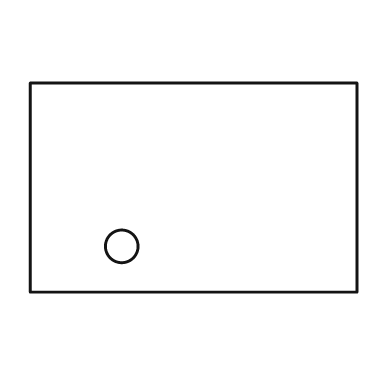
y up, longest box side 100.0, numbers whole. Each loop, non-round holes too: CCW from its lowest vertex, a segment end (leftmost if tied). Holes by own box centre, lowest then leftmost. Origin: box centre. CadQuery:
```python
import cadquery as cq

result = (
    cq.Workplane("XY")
    .moveTo(-50.0, -32.0)
    .lineTo(50.0, -32.0)
    .lineTo(50.0, 32.0)
    .lineTo(-50.0, 32.0)
    .close()
    .moveTo(-22.0, -18.0)
    .circle(5.0)
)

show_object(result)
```